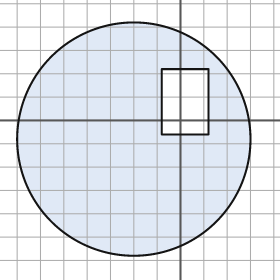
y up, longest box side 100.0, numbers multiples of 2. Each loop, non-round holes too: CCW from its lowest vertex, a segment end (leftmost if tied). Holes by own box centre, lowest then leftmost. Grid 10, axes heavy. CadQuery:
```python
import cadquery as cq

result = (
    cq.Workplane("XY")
    .moveTo(-20.0, -8.0)
    .circle(50.0)
    .moveTo(-8.0, -6.0)
    .lineTo(12.0, -6.0)
    .lineTo(12.0, 22.0)
    .lineTo(-8.0, 22.0)
    .close()
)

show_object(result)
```